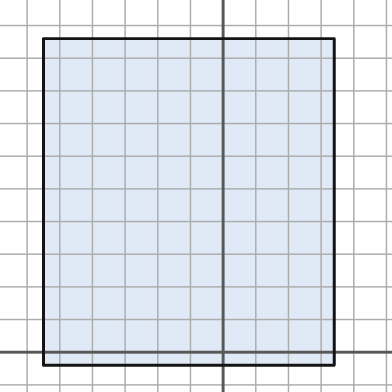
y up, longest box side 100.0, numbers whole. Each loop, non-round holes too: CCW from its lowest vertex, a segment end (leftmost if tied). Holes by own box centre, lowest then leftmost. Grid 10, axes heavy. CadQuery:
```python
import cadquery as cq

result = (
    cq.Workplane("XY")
    .moveTo(-55.0, -4.0)
    .lineTo(34.0, -4.0)
    .lineTo(34.0, 96.0)
    .lineTo(-55.0, 96.0)
    .close()
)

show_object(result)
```